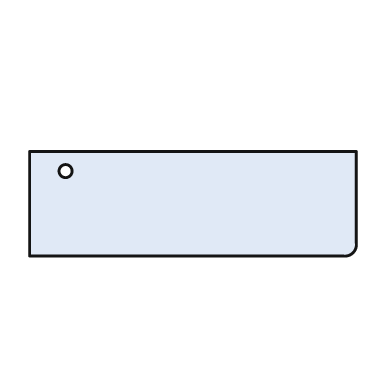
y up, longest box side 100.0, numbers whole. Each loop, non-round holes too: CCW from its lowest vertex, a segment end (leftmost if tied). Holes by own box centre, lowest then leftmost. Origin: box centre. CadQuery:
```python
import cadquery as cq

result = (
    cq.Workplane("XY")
    .moveTo(-50.0, -16.0)
    .lineTo(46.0, -16.0)
    .threePointArc((49.0, -15.0), (50.0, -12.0))
    .lineTo(50.0, 16.0)
    .lineTo(-50.0, 16.0)
    .close()
    .moveTo(-39.0, 10.0)
    .circle(2.0)
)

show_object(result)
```